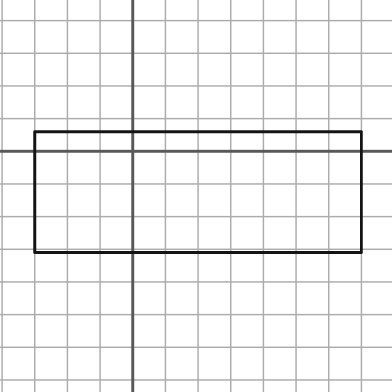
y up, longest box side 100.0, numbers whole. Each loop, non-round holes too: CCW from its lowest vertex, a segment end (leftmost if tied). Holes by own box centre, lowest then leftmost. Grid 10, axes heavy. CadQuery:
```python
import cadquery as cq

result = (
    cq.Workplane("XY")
    .moveTo(-30.0, -31.0)
    .lineTo(70.0, -31.0)
    .lineTo(70.0, 6.0)
    .lineTo(-30.0, 6.0)
    .close()
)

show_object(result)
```